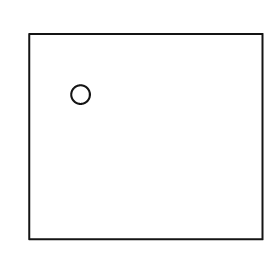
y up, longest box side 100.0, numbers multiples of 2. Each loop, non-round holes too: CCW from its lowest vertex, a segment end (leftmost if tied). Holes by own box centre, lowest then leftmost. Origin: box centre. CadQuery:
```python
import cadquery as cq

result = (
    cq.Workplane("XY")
    .moveTo(-50.0, -44.0)
    .lineTo(50.0, -44.0)
    .lineTo(50.0, 44.0)
    .lineTo(-50.0, 44.0)
    .close()
    .moveTo(-28.0, 18.0)
    .circle(4.0)
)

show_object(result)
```